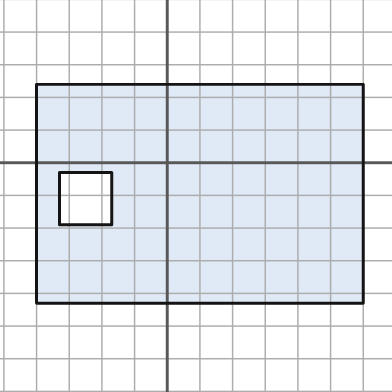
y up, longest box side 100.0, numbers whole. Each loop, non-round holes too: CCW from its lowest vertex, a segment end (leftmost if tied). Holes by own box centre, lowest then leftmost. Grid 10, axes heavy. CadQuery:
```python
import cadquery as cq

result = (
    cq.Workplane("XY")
    .moveTo(-40.0, -43.0)
    .lineTo(60.0, -43.0)
    .lineTo(60.0, 24.0)
    .lineTo(-40.0, 24.0)
    .close()
    .moveTo(-33.0, -19.0)
    .lineTo(-17.0, -19.0)
    .lineTo(-17.0, -3.0)
    .lineTo(-33.0, -3.0)
    .close()
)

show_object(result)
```